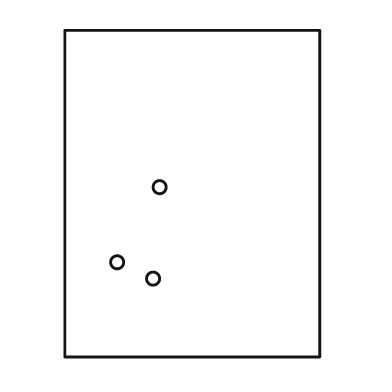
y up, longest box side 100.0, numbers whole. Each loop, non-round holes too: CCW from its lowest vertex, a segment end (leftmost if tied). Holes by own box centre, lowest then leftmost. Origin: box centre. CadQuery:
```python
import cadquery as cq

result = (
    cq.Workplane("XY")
    .moveTo(-39.0, -50.0)
    .lineTo(39.0, -50.0)
    .lineTo(39.0, 50.0)
    .lineTo(-39.0, 50.0)
    .close()
    .moveTo(-12.0, -26.0)
    .circle(2.0)
    .moveTo(-23.0, -21.0)
    .circle(2.0)
    .moveTo(-10.0, 2.0)
    .circle(2.0)
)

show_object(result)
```